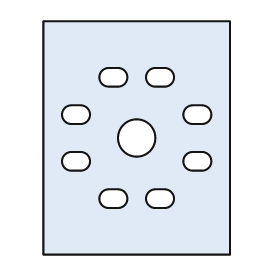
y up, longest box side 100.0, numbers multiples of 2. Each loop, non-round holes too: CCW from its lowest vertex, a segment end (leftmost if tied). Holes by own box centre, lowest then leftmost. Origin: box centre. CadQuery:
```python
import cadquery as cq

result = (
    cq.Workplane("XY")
    .moveTo(-40.0, -50.0)
    .lineTo(40.0, -50.0)
    .lineTo(40.0, 50.0)
    .lineTo(-40.0, 50.0)
    .close()
    .moveTo(-12.0, -30.0)
    .lineTo(-8.0, -30.0)
    .threePointArc((-4.0, -26.0), (-8.0, -22.0))
    .lineTo(-12.0, -22.0)
    .threePointArc((-16.0, -26.0), (-12.0, -30.0))
    .close()
    .moveTo(8.0, -30.0)
    .lineTo(12.0, -30.0)
    .threePointArc((16.0, -26.0), (12.0, -22.0))
    .lineTo(8.0, -22.0)
    .threePointArc((4.0, -26.0), (8.0, -30.0))
    .close()
    .moveTo(-28.0, -14.0)
    .lineTo(-24.0, -14.0)
    .threePointArc((-20.0, -10.0), (-24.0, -6.0))
    .lineTo(-28.0, -6.0)
    .threePointArc((-32.0, -10.0), (-28.0, -14.0))
    .close()
    .moveTo(24.0, -14.0)
    .lineTo(28.0, -14.0)
    .threePointArc((32.0, -10.0), (28.0, -6.0))
    .lineTo(24.0, -6.0)
    .threePointArc((20.0, -10.0), (24.0, -14.0))
    .close()
    .moveTo(0.0, 0.0)
    .circle(8.0)
    .moveTo(-28.0, 6.0)
    .lineTo(-24.0, 6.0)
    .threePointArc((-20.0, 10.0), (-24.0, 14.0))
    .lineTo(-28.0, 14.0)
    .threePointArc((-32.0, 10.0), (-28.0, 6.0))
    .close()
    .moveTo(24.0, 6.0)
    .lineTo(28.0, 6.0)
    .threePointArc((32.0, 10.0), (28.0, 14.0))
    .lineTo(24.0, 14.0)
    .threePointArc((20.0, 10.0), (24.0, 6.0))
    .close()
    .moveTo(-12.0, 22.0)
    .lineTo(-8.0, 22.0)
    .threePointArc((-4.0, 26.0), (-8.0, 30.0))
    .lineTo(-12.0, 30.0)
    .threePointArc((-16.0, 26.0), (-12.0, 22.0))
    .close()
    .moveTo(8.0, 22.0)
    .lineTo(12.0, 22.0)
    .threePointArc((16.0, 26.0), (12.0, 30.0))
    .lineTo(8.0, 30.0)
    .threePointArc((4.0, 26.0), (8.0, 22.0))
    .close()
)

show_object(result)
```